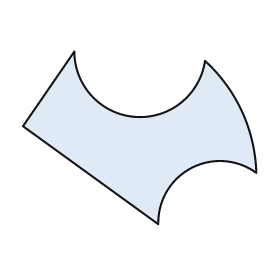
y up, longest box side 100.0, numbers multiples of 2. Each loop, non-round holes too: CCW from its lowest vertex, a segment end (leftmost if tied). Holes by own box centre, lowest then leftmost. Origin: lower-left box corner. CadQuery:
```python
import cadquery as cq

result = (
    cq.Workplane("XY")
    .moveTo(58.0, 0.0)
    .threePointArc((72.0, 24.0), (100.0, 22.0))
    .threePointArc((94.0, 48.0), (78.0, 70.0))
    .threePointArc((48.0, 46.0), (22.0, 74.0))
    .lineTo(0.0, 42.0)
    .close()
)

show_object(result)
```